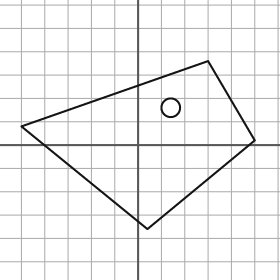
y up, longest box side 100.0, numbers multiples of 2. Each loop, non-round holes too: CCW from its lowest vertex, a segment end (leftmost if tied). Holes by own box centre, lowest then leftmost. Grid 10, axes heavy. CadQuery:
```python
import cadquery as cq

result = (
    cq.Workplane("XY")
    .moveTo(4.0, -36.0)
    .lineTo(50.0, 2.0)
    .lineTo(30.0, 36.0)
    .lineTo(-50.0, 8.0)
    .close()
    .moveTo(14.0, 16.0)
    .circle(4.0)
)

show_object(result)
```